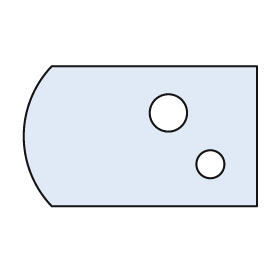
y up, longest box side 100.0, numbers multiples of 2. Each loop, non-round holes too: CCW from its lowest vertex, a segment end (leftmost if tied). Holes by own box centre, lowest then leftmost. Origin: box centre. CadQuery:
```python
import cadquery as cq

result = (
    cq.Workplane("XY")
    .moveTo(-38.0, -30.0)
    .lineTo(50.0, -30.0)
    .lineTo(50.0, 30.0)
    .lineTo(-38.0, 30.0)
    .threePointArc((-50.0, 0.0), (-38.0, -30.0))
    .close()
    .moveTo(30.0, -12.0)
    .circle(6.0)
    .moveTo(12.0, 10.0)
    .circle(8.0)
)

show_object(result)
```